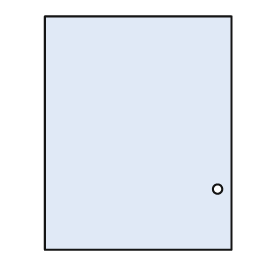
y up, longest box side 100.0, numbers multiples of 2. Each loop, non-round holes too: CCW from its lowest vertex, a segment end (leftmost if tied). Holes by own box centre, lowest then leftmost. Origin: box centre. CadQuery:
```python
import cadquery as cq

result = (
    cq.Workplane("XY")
    .moveTo(-40.0, -50.0)
    .lineTo(40.0, -50.0)
    .lineTo(40.0, 50.0)
    .lineTo(-40.0, 50.0)
    .close()
    .moveTo(34.0, -24.0)
    .circle(2.0)
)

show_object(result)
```